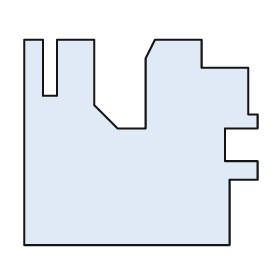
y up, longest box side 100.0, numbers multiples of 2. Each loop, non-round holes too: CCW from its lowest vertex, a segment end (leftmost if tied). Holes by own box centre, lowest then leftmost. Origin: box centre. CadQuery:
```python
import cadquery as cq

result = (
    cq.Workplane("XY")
    .moveTo(-50.0, -44.0)
    .lineTo(38.0, -44.0)
    .lineTo(38.0, -16.0)
    .lineTo(50.0, -16.0)
    .lineTo(50.0, -8.0)
    .lineTo(36.0, -8.0)
    .lineTo(36.0, 6.0)
    .lineTo(50.0, 6.0)
    .lineTo(50.0, 12.0)
    .lineTo(46.0, 12.0)
    .lineTo(46.0, 32.0)
    .lineTo(26.0, 32.0)
    .lineTo(26.0, 44.0)
    .lineTo(6.0, 44.0)
    .lineTo(2.0, 36.0)
    .lineTo(2.0, 6.0)
    .lineTo(-10.0, 6.0)
    .lineTo(-20.0, 16.0)
    .lineTo(-20.0, 44.0)
    .lineTo(-36.0, 44.0)
    .lineTo(-36.0, 20.0)
    .lineTo(-42.0, 20.0)
    .lineTo(-42.0, 44.0)
    .lineTo(-50.0, 44.0)
    .close()
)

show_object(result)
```